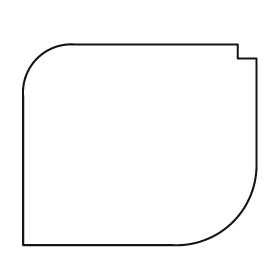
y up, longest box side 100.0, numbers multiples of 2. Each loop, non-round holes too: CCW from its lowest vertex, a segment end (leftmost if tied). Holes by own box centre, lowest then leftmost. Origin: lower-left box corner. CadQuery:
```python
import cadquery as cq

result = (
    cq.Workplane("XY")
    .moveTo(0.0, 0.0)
    .lineTo(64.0, 0.0)
    .threePointArc((90.0, 10.0), (100.0, 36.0))
    .lineTo(100.0, 80.0)
    .lineTo(92.0, 80.0)
    .lineTo(92.0, 86.0)
    .lineTo(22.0, 86.0)
    .threePointArc((6.0, 80.0), (0.0, 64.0))
    .close()
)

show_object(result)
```